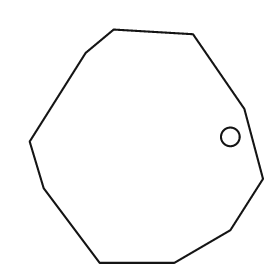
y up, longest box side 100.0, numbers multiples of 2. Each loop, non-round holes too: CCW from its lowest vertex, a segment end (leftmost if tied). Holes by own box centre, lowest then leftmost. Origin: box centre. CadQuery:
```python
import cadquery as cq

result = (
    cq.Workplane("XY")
    .moveTo(-20.0, -50.0)
    .lineTo(12.0, -50.0)
    .lineTo(36.0, -36.0)
    .lineTo(50.0, -14.0)
    .lineTo(42.0, 16.0)
    .lineTo(20.0, 48.0)
    .lineTo(-14.0, 50.0)
    .lineTo(-26.0, 40.0)
    .lineTo(-50.0, 2.0)
    .lineTo(-44.0, -18.0)
    .close()
    .moveTo(36.0, 4.0)
    .circle(4.0)
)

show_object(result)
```